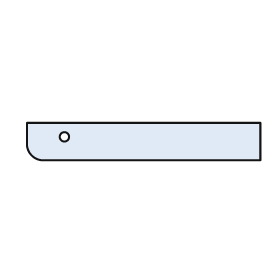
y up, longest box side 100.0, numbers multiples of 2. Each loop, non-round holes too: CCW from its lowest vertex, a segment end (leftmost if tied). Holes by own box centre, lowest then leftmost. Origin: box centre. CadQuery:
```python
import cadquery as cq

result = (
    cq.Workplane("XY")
    .moveTo(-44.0, -8.0)
    .lineTo(50.0, -8.0)
    .lineTo(50.0, 8.0)
    .lineTo(-50.0, 8.0)
    .lineTo(-50.0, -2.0)
    .threePointArc((-48.0, -6.0), (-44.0, -8.0))
    .close()
    .moveTo(-34.0, 2.0)
    .circle(2.0)
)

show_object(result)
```